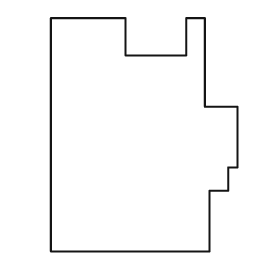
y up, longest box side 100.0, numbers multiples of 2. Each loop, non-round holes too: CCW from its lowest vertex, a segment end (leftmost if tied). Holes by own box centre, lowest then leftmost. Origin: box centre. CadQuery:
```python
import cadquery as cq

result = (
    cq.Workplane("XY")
    .moveTo(-40.0, -50.0)
    .lineTo(28.0, -50.0)
    .lineTo(28.0, -24.0)
    .lineTo(36.0, -24.0)
    .lineTo(36.0, -14.0)
    .lineTo(40.0, -14.0)
    .lineTo(40.0, 12.0)
    .lineTo(26.0, 12.0)
    .lineTo(26.0, 50.0)
    .lineTo(18.0, 50.0)
    .lineTo(18.0, 34.0)
    .lineTo(-8.0, 34.0)
    .lineTo(-8.0, 50.0)
    .lineTo(-40.0, 50.0)
    .close()
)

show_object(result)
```